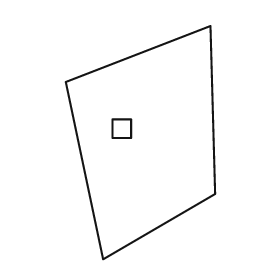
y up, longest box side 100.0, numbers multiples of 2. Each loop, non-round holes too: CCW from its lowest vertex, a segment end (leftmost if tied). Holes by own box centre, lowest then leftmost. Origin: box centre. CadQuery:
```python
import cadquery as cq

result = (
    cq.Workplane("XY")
    .moveTo(-16.0, -50.0)
    .lineTo(32.0, -22.0)
    .lineTo(30.0, 50.0)
    .lineTo(-32.0, 26.0)
    .close()
    .moveTo(-12.0, 2.0)
    .lineTo(-4.0, 2.0)
    .lineTo(-4.0, 10.0)
    .lineTo(-12.0, 10.0)
    .close()
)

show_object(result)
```